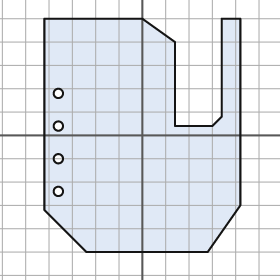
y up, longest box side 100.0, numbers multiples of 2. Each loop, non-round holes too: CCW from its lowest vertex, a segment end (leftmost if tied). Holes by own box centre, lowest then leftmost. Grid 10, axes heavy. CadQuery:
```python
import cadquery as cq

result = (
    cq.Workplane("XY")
    .moveTo(-24.0, -50.0)
    .lineTo(28.0, -50.0)
    .lineTo(42.0, -30.0)
    .lineTo(42.0, 50.0)
    .lineTo(34.0, 50.0)
    .lineTo(34.0, 8.0)
    .lineTo(30.0, 4.0)
    .lineTo(14.0, 4.0)
    .lineTo(14.0, 40.0)
    .lineTo(0.0, 50.0)
    .lineTo(-42.0, 50.0)
    .lineTo(-42.0, -32.0)
    .close()
    .moveTo(-36.0, -24.0)
    .circle(2.0)
    .moveTo(-36.0, -10.0)
    .circle(2.0)
    .moveTo(-36.0, 4.0)
    .circle(2.0)
    .moveTo(-36.0, 18.0)
    .circle(2.0)
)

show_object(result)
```